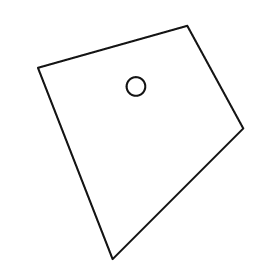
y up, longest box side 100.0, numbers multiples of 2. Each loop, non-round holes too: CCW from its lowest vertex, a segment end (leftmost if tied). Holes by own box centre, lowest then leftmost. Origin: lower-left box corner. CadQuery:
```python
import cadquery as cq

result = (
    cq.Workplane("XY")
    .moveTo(32.0, 0.0)
    .lineTo(88.0, 56.0)
    .lineTo(64.0, 100.0)
    .lineTo(0.0, 82.0)
    .close()
    .moveTo(42.0, 74.0)
    .circle(4.0)
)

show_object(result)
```